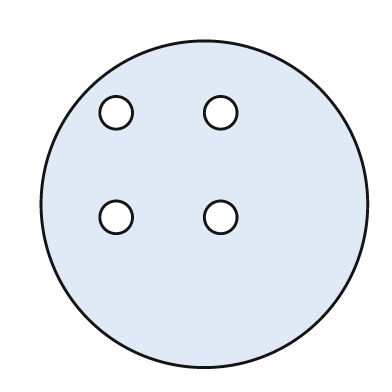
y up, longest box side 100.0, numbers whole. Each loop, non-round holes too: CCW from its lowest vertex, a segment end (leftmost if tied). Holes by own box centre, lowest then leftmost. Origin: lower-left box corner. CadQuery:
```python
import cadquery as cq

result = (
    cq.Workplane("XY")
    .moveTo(50.0, 50.0)
    .circle(50.0)
    .moveTo(23.0, 46.0)
    .circle(5.0)
    .moveTo(55.0, 46.0)
    .circle(5.0)
    .moveTo(23.0, 78.0)
    .circle(5.0)
    .moveTo(55.0, 78.0)
    .circle(5.0)
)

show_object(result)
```